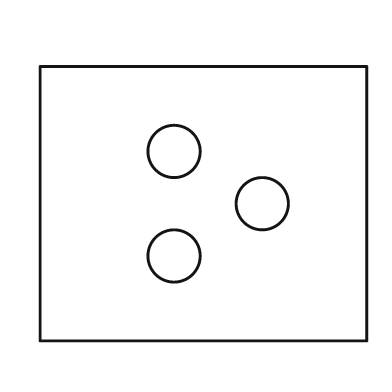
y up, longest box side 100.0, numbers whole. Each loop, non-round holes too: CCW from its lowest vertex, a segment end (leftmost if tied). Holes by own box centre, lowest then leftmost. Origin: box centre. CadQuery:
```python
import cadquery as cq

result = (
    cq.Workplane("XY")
    .moveTo(-50.0, -42.0)
    .lineTo(50.0, -42.0)
    .lineTo(50.0, 42.0)
    .lineTo(-50.0, 42.0)
    .close()
    .moveTo(-9.0, -16.0)
    .circle(8.0)
    .moveTo(18.0, 0.0)
    .circle(8.0)
    .moveTo(-9.0, 16.0)
    .circle(8.0)
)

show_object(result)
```